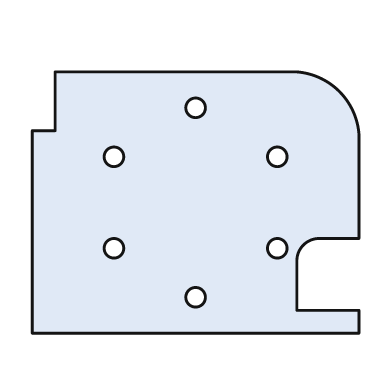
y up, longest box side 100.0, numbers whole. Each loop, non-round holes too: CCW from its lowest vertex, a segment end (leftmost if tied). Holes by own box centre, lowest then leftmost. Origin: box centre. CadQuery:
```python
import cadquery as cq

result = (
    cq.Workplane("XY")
    .moveTo(-50.0, -40.0)
    .lineTo(50.0, -40.0)
    .lineTo(50.0, -33.0)
    .lineTo(31.0, -33.0)
    .lineTo(31.0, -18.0)
    .threePointArc((33.0, -13.0), (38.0, -11.0))
    .lineTo(50.0, -11.0)
    .lineTo(50.0, 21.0)
    .threePointArc((44.0, 34.0), (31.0, 40.0))
    .lineTo(-43.0, 40.0)
    .lineTo(-43.0, 22.0)
    .lineTo(-50.0, 22.0)
    .close()
    .moveTo(0.0, -29.0)
    .circle(3.0)
    .moveTo(-25.0, -14.0)
    .circle(3.0)
    .moveTo(25.0, -14.0)
    .circle(3.0)
    .moveTo(-25.0, 14.0)
    .circle(3.0)
    .moveTo(25.0, 14.0)
    .circle(3.0)
    .moveTo(0.0, 29.0)
    .circle(3.0)
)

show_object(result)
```